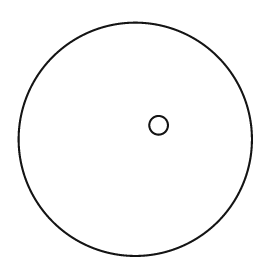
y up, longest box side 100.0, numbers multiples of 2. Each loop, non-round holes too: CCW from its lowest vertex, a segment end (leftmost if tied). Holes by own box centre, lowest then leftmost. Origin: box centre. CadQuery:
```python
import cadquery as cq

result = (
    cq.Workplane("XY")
    .moveTo(0.0, 0.0)
    .circle(50.0)
    .moveTo(10.0, 6.0)
    .circle(4.0)
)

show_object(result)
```